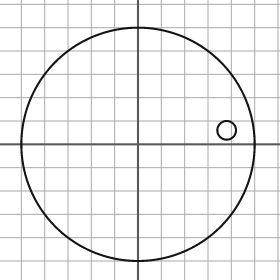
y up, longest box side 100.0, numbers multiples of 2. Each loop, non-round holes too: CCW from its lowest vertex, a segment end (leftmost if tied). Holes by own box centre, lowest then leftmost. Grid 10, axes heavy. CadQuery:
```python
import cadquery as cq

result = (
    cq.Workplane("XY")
    .moveTo(0.0, 0.0)
    .circle(50.0)
    .moveTo(38.0, 6.0)
    .circle(4.0)
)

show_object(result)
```